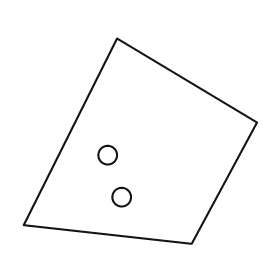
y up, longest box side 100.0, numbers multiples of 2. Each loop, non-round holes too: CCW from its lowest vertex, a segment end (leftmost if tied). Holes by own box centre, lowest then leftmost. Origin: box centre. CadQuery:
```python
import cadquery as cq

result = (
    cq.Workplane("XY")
    .moveTo(22.0, -44.0)
    .lineTo(50.0, 8.0)
    .lineTo(-10.0, 44.0)
    .lineTo(-50.0, -36.0)
    .close()
    .moveTo(-8.0, -24.0)
    .circle(4.0)
    .moveTo(-14.0, -6.0)
    .circle(4.0)
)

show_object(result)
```